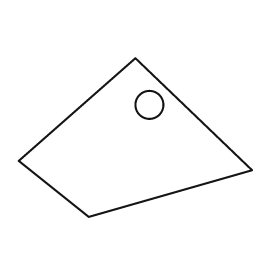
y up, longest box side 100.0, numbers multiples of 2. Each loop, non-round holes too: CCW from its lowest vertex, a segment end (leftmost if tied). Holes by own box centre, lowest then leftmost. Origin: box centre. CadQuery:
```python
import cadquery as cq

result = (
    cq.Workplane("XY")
    .moveTo(-20.0, -34.0)
    .lineTo(50.0, -14.0)
    .lineTo(0.0, 34.0)
    .lineTo(-50.0, -10.0)
    .close()
    .moveTo(6.0, 14.0)
    .circle(6.0)
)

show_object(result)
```